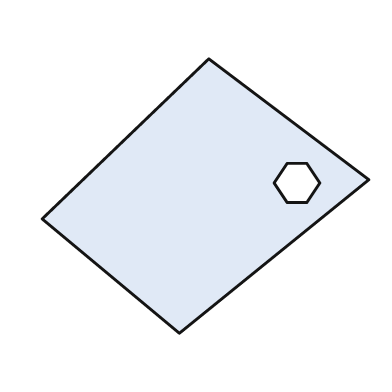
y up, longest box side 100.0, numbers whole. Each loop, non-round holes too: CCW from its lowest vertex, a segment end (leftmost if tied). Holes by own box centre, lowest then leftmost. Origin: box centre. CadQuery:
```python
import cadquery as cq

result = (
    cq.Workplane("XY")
    .moveTo(-8.0, -42.0)
    .lineTo(50.0, 5.0)
    .lineTo(1.0, 42.0)
    .lineTo(-50.0, -7.0)
    .close()
    .moveTo(25.0, -2.0)
    .lineTo(31.0, -2.0)
    .lineTo(35.0, 4.0)
    .lineTo(31.0, 10.0)
    .lineTo(25.0, 10.0)
    .lineTo(21.0, 4.0)
    .close()
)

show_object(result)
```